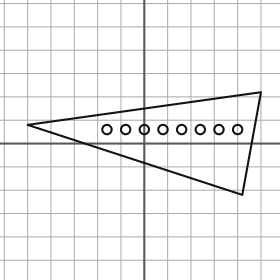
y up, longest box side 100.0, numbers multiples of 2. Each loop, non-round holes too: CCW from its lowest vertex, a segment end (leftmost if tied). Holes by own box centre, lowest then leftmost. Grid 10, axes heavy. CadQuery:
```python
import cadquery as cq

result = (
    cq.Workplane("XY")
    .moveTo(42.0, -22.0)
    .lineTo(50.0, 22.0)
    .lineTo(-50.0, 8.0)
    .close()
    .moveTo(-16.0, 6.0)
    .circle(2.0)
    .moveTo(-8.0, 6.0)
    .circle(2.0)
    .moveTo(0.0, 6.0)
    .circle(2.0)
    .moveTo(8.0, 6.0)
    .circle(2.0)
    .moveTo(16.0, 6.0)
    .circle(2.0)
    .moveTo(24.0, 6.0)
    .circle(2.0)
    .moveTo(32.0, 6.0)
    .circle(2.0)
    .moveTo(40.0, 6.0)
    .circle(2.0)
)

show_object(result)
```